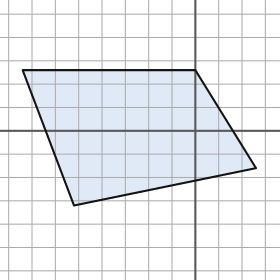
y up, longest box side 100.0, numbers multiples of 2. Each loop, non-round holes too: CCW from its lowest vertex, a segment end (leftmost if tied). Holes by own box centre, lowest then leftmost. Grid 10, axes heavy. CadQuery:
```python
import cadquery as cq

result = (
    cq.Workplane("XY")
    .moveTo(-52.0, -32.0)
    .lineTo(26.0, -16.0)
    .lineTo(0.0, 26.0)
    .lineTo(-74.0, 26.0)
    .close()
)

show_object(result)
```